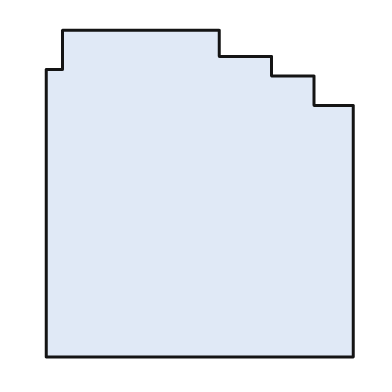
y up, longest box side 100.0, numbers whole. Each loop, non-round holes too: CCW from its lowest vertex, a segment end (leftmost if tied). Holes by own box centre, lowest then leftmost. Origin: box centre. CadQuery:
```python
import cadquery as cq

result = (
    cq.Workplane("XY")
    .moveTo(-47.0, -50.0)
    .lineTo(47.0, -50.0)
    .lineTo(47.0, 27.0)
    .lineTo(35.0, 27.0)
    .lineTo(35.0, 36.0)
    .lineTo(22.0, 36.0)
    .lineTo(22.0, 42.0)
    .lineTo(6.0, 42.0)
    .lineTo(6.0, 50.0)
    .lineTo(-42.0, 50.0)
    .lineTo(-42.0, 38.0)
    .lineTo(-47.0, 38.0)
    .close()
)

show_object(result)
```